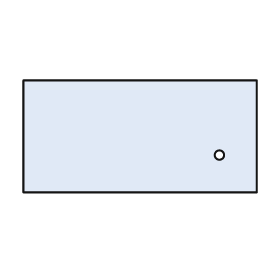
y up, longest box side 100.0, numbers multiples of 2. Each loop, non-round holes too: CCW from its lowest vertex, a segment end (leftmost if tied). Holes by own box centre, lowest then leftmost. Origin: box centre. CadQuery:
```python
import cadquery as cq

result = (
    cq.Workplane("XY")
    .moveTo(-50.0, -24.0)
    .lineTo(50.0, -24.0)
    .lineTo(50.0, 24.0)
    .lineTo(-50.0, 24.0)
    .close()
    .moveTo(34.0, -8.0)
    .circle(2.0)
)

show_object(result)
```